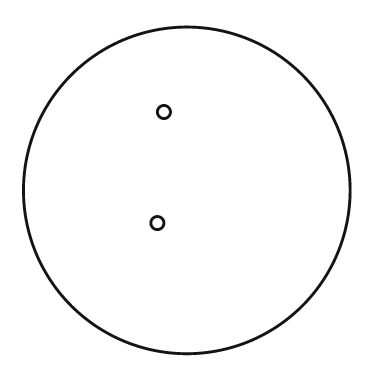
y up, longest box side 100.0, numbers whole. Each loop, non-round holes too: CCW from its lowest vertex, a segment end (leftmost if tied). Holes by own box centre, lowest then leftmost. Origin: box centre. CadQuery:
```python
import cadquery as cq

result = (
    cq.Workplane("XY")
    .moveTo(0.0, 0.0)
    .circle(50.0)
    .moveTo(-9.0, -10.0)
    .circle(2.0)
    .moveTo(-7.0, 24.0)
    .circle(2.0)
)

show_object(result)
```